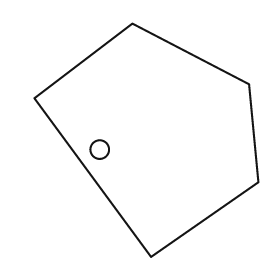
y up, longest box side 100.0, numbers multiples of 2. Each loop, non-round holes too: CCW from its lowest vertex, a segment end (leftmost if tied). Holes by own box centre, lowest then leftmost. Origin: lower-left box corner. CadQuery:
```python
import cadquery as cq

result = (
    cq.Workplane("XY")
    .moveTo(50.0, 0.0)
    .lineTo(96.0, 32.0)
    .lineTo(92.0, 74.0)
    .lineTo(42.0, 100.0)
    .lineTo(0.0, 68.0)
    .close()
    .moveTo(28.0, 46.0)
    .circle(4.0)
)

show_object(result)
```